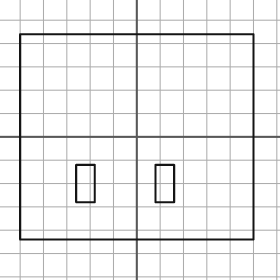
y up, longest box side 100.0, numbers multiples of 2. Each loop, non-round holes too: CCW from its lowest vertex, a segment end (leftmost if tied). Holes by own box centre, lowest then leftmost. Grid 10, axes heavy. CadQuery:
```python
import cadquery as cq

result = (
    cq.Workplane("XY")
    .moveTo(-50.0, -44.0)
    .lineTo(50.0, -44.0)
    .lineTo(50.0, 44.0)
    .lineTo(-50.0, 44.0)
    .close()
    .moveTo(-26.0, -28.0)
    .lineTo(-18.0, -28.0)
    .lineTo(-18.0, -12.0)
    .lineTo(-26.0, -12.0)
    .close()
    .moveTo(8.0, -28.0)
    .lineTo(16.0, -28.0)
    .lineTo(16.0, -12.0)
    .lineTo(8.0, -12.0)
    .close()
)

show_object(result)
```